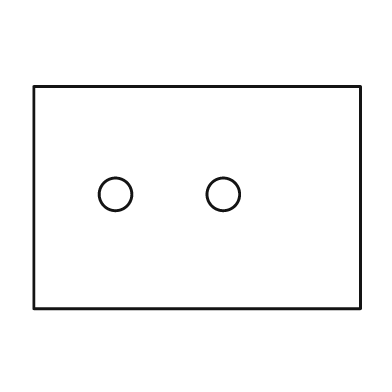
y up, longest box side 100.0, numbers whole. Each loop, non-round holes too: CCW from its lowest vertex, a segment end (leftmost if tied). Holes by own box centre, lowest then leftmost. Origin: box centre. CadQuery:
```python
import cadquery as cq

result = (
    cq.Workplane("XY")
    .moveTo(-50.0, -34.0)
    .lineTo(50.0, -34.0)
    .lineTo(50.0, 34.0)
    .lineTo(-50.0, 34.0)
    .close()
    .moveTo(-25.0, 1.0)
    .circle(5.0)
    .moveTo(8.0, 1.0)
    .circle(5.0)
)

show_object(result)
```